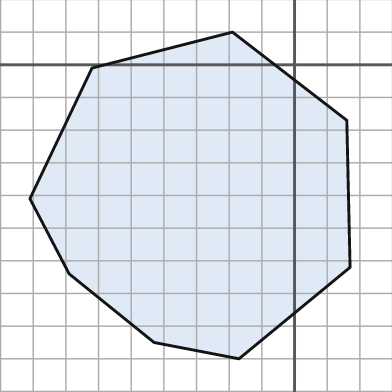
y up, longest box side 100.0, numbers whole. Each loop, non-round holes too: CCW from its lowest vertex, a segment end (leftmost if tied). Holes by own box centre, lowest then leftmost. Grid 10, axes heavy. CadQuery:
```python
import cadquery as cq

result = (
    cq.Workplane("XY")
    .moveTo(-17.0, -90.0)
    .lineTo(17.0, -62.0)
    .lineTo(16.0, -17.0)
    .lineTo(-19.0, 10.0)
    .lineTo(-62.0, -1.0)
    .lineTo(-81.0, -41.0)
    .lineTo(-69.0, -64.0)
    .lineTo(-43.0, -85.0)
    .close()
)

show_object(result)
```